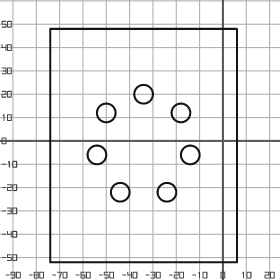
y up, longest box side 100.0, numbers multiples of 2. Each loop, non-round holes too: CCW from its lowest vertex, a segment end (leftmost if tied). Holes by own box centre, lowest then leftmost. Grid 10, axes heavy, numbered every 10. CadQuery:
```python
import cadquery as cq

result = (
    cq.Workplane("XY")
    .moveTo(-74.0, -52.0)
    .lineTo(6.0, -52.0)
    .lineTo(6.0, 48.0)
    .lineTo(-74.0, 48.0)
    .close()
    .moveTo(-44.0, -22.0)
    .circle(4.0)
    .moveTo(-24.0, -22.0)
    .circle(4.0)
    .moveTo(-54.0, -6.0)
    .circle(4.0)
    .moveTo(-14.0, -6.0)
    .circle(4.0)
    .moveTo(-50.0, 12.0)
    .circle(4.0)
    .moveTo(-18.0, 12.0)
    .circle(4.0)
    .moveTo(-34.0, 20.0)
    .circle(4.0)
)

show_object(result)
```